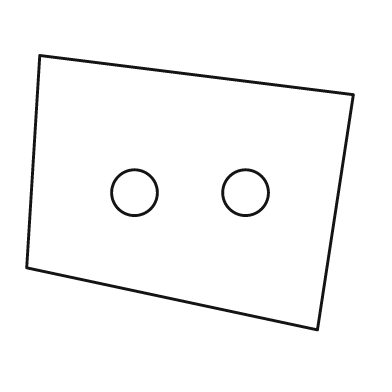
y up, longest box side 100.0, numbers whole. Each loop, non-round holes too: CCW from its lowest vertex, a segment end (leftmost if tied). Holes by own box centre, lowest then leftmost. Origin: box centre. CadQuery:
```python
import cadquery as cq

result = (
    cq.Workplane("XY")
    .moveTo(39.0, -42.0)
    .lineTo(50.0, 30.0)
    .lineTo(-46.0, 42.0)
    .lineTo(-50.0, -23.0)
    .close()
    .moveTo(-17.0, 0.0)
    .circle(7.0)
    .moveTo(17.0, 0.0)
    .circle(7.0)
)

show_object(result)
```